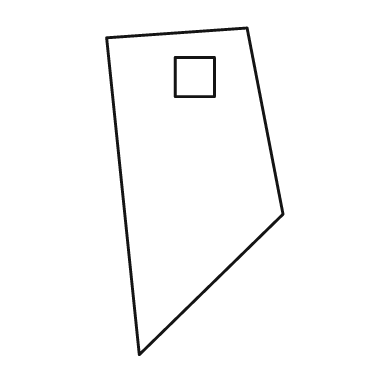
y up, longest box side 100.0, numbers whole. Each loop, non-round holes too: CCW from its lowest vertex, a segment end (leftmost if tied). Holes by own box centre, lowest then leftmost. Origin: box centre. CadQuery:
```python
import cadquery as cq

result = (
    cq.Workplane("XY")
    .moveTo(-17.0, -50.0)
    .lineTo(27.0, -7.0)
    .lineTo(16.0, 50.0)
    .lineTo(-27.0, 47.0)
    .close()
    .moveTo(-6.0, 29.0)
    .lineTo(6.0, 29.0)
    .lineTo(6.0, 41.0)
    .lineTo(-6.0, 41.0)
    .close()
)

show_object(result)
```